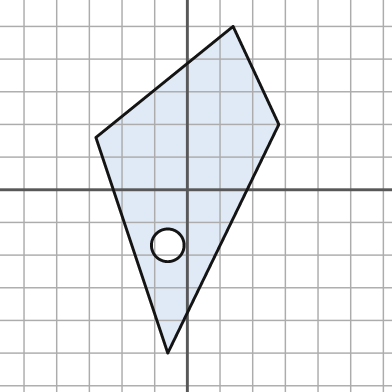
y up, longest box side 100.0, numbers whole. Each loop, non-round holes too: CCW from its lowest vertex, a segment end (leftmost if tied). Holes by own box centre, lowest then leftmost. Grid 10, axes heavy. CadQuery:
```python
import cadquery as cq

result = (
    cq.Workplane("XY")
    .moveTo(-6.0, -50.0)
    .lineTo(28.0, 20.0)
    .lineTo(14.0, 50.0)
    .lineTo(-28.0, 16.0)
    .close()
    .moveTo(-6.0, -17.0)
    .circle(5.0)
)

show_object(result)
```